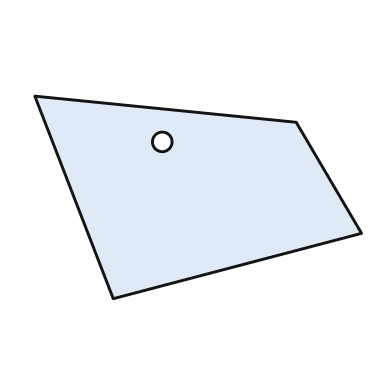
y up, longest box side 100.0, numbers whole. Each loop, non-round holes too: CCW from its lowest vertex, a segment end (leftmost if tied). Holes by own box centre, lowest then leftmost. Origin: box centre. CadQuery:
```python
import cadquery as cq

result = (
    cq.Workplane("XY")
    .moveTo(-26.0, -31.0)
    .lineTo(50.0, -11.0)
    .lineTo(30.0, 23.0)
    .lineTo(-50.0, 31.0)
    .close()
    .moveTo(-11.0, 17.0)
    .circle(3.0)
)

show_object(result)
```